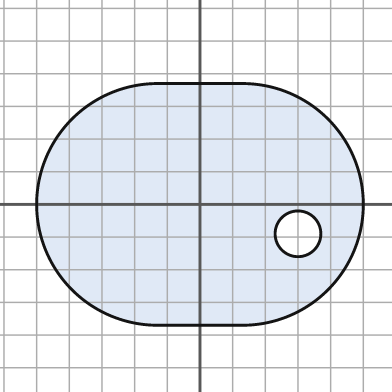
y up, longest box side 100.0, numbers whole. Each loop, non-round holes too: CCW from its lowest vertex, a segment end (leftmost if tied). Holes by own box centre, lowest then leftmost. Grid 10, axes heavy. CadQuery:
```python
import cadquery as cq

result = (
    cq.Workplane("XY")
    .moveTo(-13.0, -37.0)
    .lineTo(13.0, -37.0)
    .threePointArc((50.0, 0.0), (13.0, 37.0))
    .lineTo(-13.0, 37.0)
    .threePointArc((-50.0, 0.0), (-13.0, -37.0))
    .close()
    .moveTo(30.0, -9.0)
    .circle(7.0)
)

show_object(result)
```